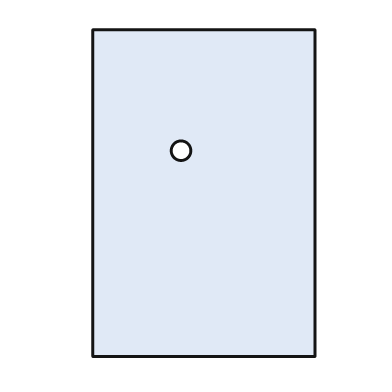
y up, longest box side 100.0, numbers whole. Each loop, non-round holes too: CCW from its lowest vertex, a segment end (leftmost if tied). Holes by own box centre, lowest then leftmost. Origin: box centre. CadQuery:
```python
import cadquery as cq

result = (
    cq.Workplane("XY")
    .moveTo(-34.0, -50.0)
    .lineTo(34.0, -50.0)
    .lineTo(34.0, 50.0)
    .lineTo(-34.0, 50.0)
    .close()
    .moveTo(-7.0, 13.0)
    .circle(3.0)
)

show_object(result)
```